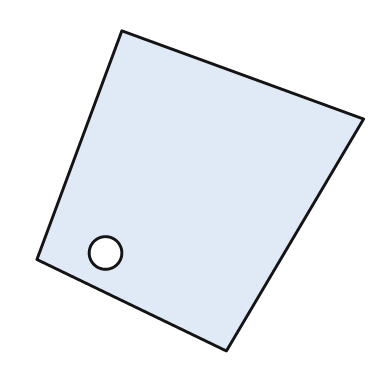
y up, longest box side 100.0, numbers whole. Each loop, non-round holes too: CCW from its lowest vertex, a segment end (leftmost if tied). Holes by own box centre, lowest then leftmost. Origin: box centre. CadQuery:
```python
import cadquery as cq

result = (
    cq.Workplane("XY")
    .moveTo(8.0, -49.0)
    .lineTo(50.0, 22.0)
    .lineTo(-24.0, 49.0)
    .lineTo(-50.0, -21.0)
    .close()
    .moveTo(-29.0, -19.0)
    .circle(5.0)
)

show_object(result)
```